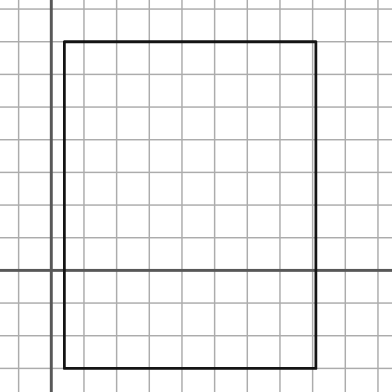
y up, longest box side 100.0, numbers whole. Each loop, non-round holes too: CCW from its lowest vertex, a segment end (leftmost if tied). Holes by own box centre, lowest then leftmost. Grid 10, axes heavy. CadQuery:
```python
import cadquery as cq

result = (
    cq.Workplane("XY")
    .moveTo(4.0, -30.0)
    .lineTo(81.0, -30.0)
    .lineTo(81.0, 70.0)
    .lineTo(4.0, 70.0)
    .close()
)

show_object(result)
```